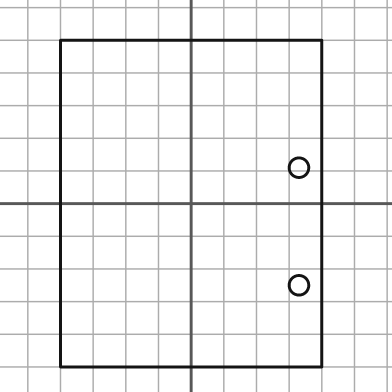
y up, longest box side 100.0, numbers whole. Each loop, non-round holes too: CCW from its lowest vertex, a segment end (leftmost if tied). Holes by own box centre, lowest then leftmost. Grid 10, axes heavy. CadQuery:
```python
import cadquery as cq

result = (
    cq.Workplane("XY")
    .moveTo(-40.0, -50.0)
    .lineTo(40.0, -50.0)
    .lineTo(40.0, 50.0)
    .lineTo(-40.0, 50.0)
    .close()
    .moveTo(33.0, -25.0)
    .circle(3.0)
    .moveTo(33.0, 11.0)
    .circle(3.0)
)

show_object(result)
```